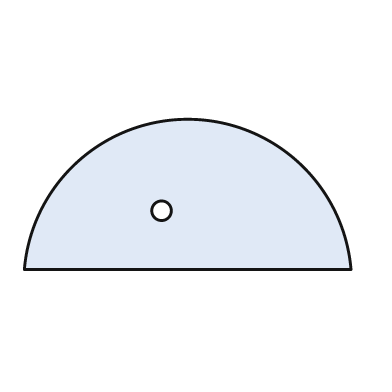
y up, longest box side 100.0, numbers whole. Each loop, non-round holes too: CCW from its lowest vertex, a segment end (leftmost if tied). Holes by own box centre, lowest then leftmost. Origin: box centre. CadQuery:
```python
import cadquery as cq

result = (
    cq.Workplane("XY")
    .moveTo(-50.0, -23.0)
    .lineTo(50.0, -23.0)
    .threePointArc((0.0, 23.0), (-50.0, -23.0))
    .close()
    .moveTo(-8.0, -5.0)
    .circle(3.0)
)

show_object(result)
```